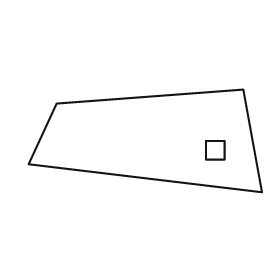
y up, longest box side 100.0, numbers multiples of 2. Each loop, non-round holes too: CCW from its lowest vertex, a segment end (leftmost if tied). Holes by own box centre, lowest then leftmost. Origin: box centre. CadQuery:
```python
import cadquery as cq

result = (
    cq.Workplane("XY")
    .moveTo(50.0, -22.0)
    .lineTo(42.0, 22.0)
    .lineTo(-38.0, 16.0)
    .lineTo(-50.0, -10.0)
    .close()
    .moveTo(26.0, -8.0)
    .lineTo(34.0, -8.0)
    .lineTo(34.0, 0.0)
    .lineTo(26.0, 0.0)
    .close()
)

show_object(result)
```